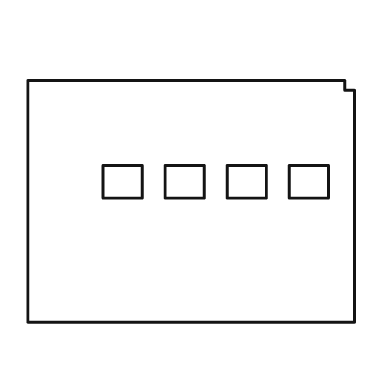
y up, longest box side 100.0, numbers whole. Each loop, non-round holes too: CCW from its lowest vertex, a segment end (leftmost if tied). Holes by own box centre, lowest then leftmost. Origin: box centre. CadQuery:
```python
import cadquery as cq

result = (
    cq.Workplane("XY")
    .moveTo(-50.0, -37.0)
    .lineTo(50.0, -37.0)
    .lineTo(50.0, 34.0)
    .lineTo(47.0, 34.0)
    .lineTo(47.0, 37.0)
    .lineTo(-50.0, 37.0)
    .close()
    .moveTo(-27.0, 1.0)
    .lineTo(-15.0, 1.0)
    .lineTo(-15.0, 11.0)
    .lineTo(-27.0, 11.0)
    .close()
    .moveTo(-8.0, 1.0)
    .lineTo(4.0, 1.0)
    .lineTo(4.0, 11.0)
    .lineTo(-8.0, 11.0)
    .close()
    .moveTo(11.0, 1.0)
    .lineTo(23.0, 1.0)
    .lineTo(23.0, 11.0)
    .lineTo(11.0, 11.0)
    .close()
    .moveTo(30.0, 1.0)
    .lineTo(42.0, 1.0)
    .lineTo(42.0, 11.0)
    .lineTo(30.0, 11.0)
    .close()
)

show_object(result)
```